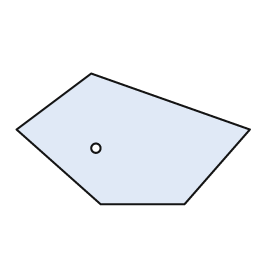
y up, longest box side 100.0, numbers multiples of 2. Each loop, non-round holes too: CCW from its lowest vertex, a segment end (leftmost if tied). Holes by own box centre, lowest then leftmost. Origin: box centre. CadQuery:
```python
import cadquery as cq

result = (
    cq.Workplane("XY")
    .moveTo(-14.0, -28.0)
    .lineTo(22.0, -28.0)
    .lineTo(50.0, 4.0)
    .lineTo(-18.0, 28.0)
    .lineTo(-50.0, 4.0)
    .close()
    .moveTo(-16.0, -4.0)
    .circle(2.0)
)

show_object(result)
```